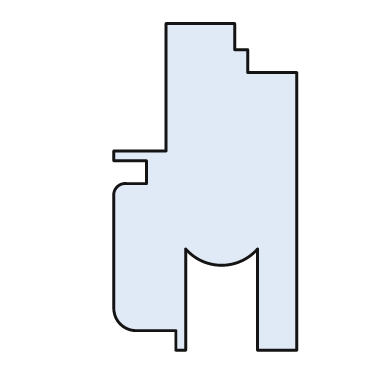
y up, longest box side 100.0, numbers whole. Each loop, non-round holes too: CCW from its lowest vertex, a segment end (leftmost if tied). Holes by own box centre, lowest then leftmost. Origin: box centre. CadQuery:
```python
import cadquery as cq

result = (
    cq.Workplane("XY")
    .moveTo(-9.0, -50.0)
    .lineTo(-6.0, -50.0)
    .lineTo(-6.0, -19.0)
    .threePointArc((5.0, -24.0), (16.0, -19.0))
    .lineTo(16.0, -50.0)
    .lineTo(28.0, -50.0)
    .lineTo(28.0, 35.0)
    .lineTo(13.0, 35.0)
    .lineTo(13.0, 42.0)
    .lineTo(9.0, 42.0)
    .lineTo(9.0, 50.0)
    .lineTo(-12.0, 50.0)
    .lineTo(-12.0, 11.0)
    .lineTo(-28.0, 11.0)
    .lineTo(-28.0, 8.0)
    .lineTo(-18.0, 8.0)
    .lineTo(-18.0, 1.0)
    .lineTo(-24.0, 1.0)
    .threePointArc((-27.0, 0.0), (-28.0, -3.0))
    .lineTo(-28.0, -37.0)
    .threePointArc((-26.0, -42.0), (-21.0, -44.0))
    .lineTo(-9.0, -44.0)
    .close()
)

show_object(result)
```